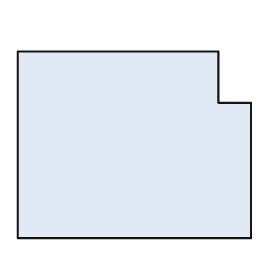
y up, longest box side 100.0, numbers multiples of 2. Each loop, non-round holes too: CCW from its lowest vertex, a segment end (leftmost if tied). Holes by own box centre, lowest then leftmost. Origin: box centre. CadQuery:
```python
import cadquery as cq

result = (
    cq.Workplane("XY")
    .moveTo(-50.0, -40.0)
    .lineTo(50.0, -40.0)
    .lineTo(50.0, 18.0)
    .lineTo(36.0, 18.0)
    .lineTo(36.0, 40.0)
    .lineTo(-50.0, 40.0)
    .close()
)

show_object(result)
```